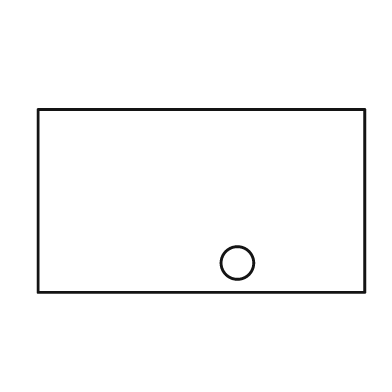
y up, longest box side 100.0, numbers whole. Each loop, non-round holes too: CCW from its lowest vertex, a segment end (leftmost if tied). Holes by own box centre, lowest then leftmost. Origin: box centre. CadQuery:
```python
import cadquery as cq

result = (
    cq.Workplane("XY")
    .moveTo(-50.0, -28.0)
    .lineTo(50.0, -28.0)
    .lineTo(50.0, 28.0)
    .lineTo(-50.0, 28.0)
    .close()
    .moveTo(11.0, -19.0)
    .circle(5.0)
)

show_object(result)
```